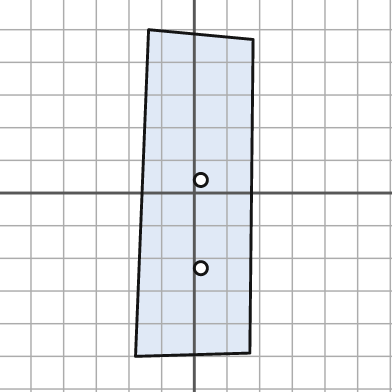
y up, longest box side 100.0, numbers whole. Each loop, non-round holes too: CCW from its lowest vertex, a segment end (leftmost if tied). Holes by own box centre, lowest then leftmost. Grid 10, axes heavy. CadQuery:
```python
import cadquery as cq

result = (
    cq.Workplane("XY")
    .moveTo(-18.0, -50.0)
    .lineTo(17.0, -49.0)
    .lineTo(18.0, 47.0)
    .lineTo(-14.0, 50.0)
    .close()
    .moveTo(2.0, -23.0)
    .circle(2.0)
    .moveTo(2.0, 4.0)
    .circle(2.0)
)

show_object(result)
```